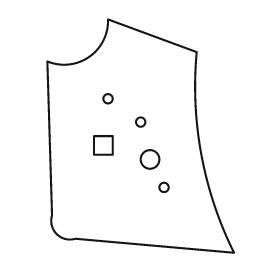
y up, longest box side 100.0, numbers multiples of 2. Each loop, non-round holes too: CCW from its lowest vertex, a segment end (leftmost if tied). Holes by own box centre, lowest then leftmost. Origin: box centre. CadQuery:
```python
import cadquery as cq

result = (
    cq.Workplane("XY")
    .moveTo(40.0, -50.0)
    .threePointArc((26.0, -8.0), (24.0, 36.0))
    .lineTo(-14.0, 50.0)
    .threePointArc((-22.0, 34.0), (-40.0, 32.0))
    .lineTo(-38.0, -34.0)
    .threePointArc((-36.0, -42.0), (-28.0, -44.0))
    .close()
    .moveTo(10.0, -22.0)
    .circle(2.0)
    .moveTo(4.0, -10.0)
    .circle(4.0)
    .moveTo(-20.0, -8.0)
    .lineTo(-12.0, -8.0)
    .lineTo(-12.0, 0.0)
    .lineTo(-20.0, 0.0)
    .close()
    .moveTo(0.0, 6.0)
    .circle(2.0)
    .moveTo(-14.0, 16.0)
    .circle(2.0)
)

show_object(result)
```